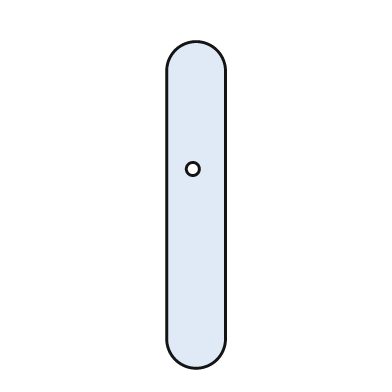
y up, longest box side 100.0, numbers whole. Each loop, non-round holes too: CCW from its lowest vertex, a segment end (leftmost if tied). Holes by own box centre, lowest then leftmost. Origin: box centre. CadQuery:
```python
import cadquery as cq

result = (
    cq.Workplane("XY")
    .moveTo(-9.0, -41.0)
    .threePointArc((0.0, -50.0), (9.0, -41.0))
    .lineTo(9.0, 41.0)
    .threePointArc((0.0, 50.0), (-9.0, 41.0))
    .close()
    .moveTo(-1.0, 11.0)
    .circle(2.0)
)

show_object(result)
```